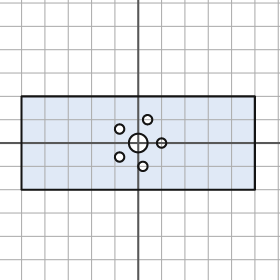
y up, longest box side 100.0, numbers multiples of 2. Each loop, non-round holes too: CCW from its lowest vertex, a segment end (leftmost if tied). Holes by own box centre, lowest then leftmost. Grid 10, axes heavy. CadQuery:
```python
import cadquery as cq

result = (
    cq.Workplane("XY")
    .moveTo(-50.0, -20.0)
    .lineTo(50.0, -20.0)
    .lineTo(50.0, 20.0)
    .lineTo(-50.0, 20.0)
    .close()
    .moveTo(2.0, -10.0)
    .circle(2.0)
    .moveTo(-8.0, -6.0)
    .circle(2.0)
    .moveTo(0.0, 0.0)
    .circle(4.0)
    .moveTo(10.0, 0.0)
    .circle(2.0)
    .moveTo(-8.0, 6.0)
    .circle(2.0)
    .moveTo(4.0, 10.0)
    .circle(2.0)
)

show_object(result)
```